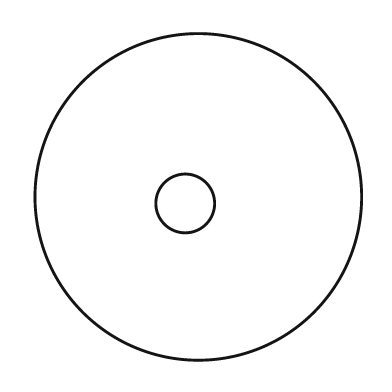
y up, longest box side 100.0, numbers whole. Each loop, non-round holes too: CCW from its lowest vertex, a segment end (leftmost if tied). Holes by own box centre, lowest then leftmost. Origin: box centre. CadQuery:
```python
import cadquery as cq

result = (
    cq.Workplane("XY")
    .moveTo(0.0, 0.0)
    .circle(50.0)
    .moveTo(-4.0, -2.0)
    .circle(9.0)
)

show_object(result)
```